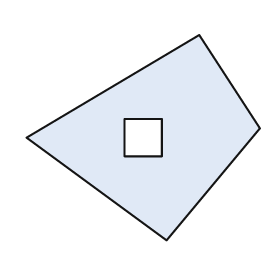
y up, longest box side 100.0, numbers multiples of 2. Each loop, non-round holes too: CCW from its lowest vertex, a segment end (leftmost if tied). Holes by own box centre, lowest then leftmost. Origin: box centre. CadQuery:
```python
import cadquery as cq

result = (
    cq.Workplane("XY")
    .moveTo(10.0, -44.0)
    .lineTo(50.0, 4.0)
    .lineTo(24.0, 44.0)
    .lineTo(-50.0, 0.0)
    .close()
    .moveTo(-8.0, -8.0)
    .lineTo(8.0, -8.0)
    .lineTo(8.0, 8.0)
    .lineTo(-8.0, 8.0)
    .close()
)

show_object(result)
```